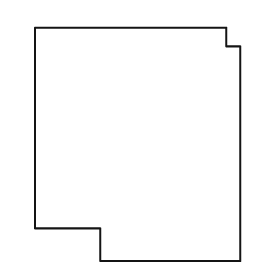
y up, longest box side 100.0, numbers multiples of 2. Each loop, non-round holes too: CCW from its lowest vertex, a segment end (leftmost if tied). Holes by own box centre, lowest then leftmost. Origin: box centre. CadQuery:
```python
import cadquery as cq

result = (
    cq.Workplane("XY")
    .moveTo(-16.0, -50.0)
    .lineTo(44.0, -50.0)
    .lineTo(44.0, 42.0)
    .lineTo(38.0, 42.0)
    .lineTo(38.0, 50.0)
    .lineTo(-44.0, 50.0)
    .lineTo(-44.0, -36.0)
    .lineTo(-16.0, -36.0)
    .close()
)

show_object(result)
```